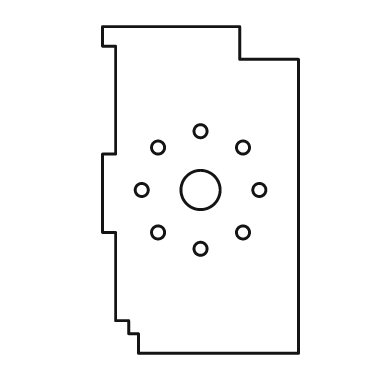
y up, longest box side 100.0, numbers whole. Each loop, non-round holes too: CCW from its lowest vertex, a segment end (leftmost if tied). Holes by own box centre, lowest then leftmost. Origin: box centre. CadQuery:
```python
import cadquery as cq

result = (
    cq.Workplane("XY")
    .moveTo(-19.0, -50.0)
    .lineTo(30.0, -50.0)
    .lineTo(30.0, 40.0)
    .lineTo(12.0, 40.0)
    .lineTo(12.0, 50.0)
    .lineTo(-30.0, 50.0)
    .lineTo(-30.0, 44.0)
    .lineTo(-26.0, 44.0)
    .lineTo(-26.0, 11.0)
    .lineTo(-30.0, 11.0)
    .lineTo(-30.0, -13.0)
    .lineTo(-26.0, -13.0)
    .lineTo(-26.0, -40.0)
    .lineTo(-22.0, -40.0)
    .lineTo(-22.0, -44.0)
    .lineTo(-19.0, -44.0)
    .close()
    .moveTo(0.0, -18.0)
    .circle(2.0)
    .moveTo(-13.0, -13.0)
    .circle(2.0)
    .moveTo(13.0, -13.0)
    .circle(2.0)
    .moveTo(-18.0, 0.0)
    .circle(2.0)
    .moveTo(0.0, 0.0)
    .circle(6.0)
    .moveTo(18.0, 0.0)
    .circle(2.0)
    .moveTo(-13.0, 13.0)
    .circle(2.0)
    .moveTo(13.0, 13.0)
    .circle(2.0)
    .moveTo(0.0, 18.0)
    .circle(2.0)
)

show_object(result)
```